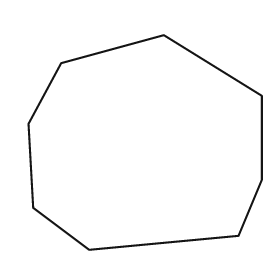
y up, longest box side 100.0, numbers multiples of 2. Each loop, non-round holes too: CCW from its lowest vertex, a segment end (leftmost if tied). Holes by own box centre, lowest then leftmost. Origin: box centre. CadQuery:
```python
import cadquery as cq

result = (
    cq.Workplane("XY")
    .moveTo(-24.0, -46.0)
    .lineTo(40.0, -40.0)
    .lineTo(50.0, -16.0)
    .lineTo(50.0, 20.0)
    .lineTo(8.0, 46.0)
    .lineTo(-36.0, 34.0)
    .lineTo(-50.0, 8.0)
    .lineTo(-48.0, -28.0)
    .close()
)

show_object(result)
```